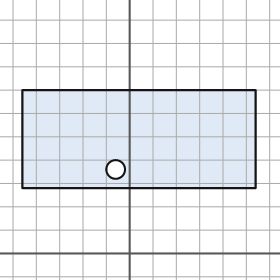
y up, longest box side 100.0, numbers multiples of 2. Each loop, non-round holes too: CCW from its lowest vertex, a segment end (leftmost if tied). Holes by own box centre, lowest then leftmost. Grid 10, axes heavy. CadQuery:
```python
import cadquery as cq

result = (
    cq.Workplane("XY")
    .moveTo(-46.0, 28.0)
    .lineTo(54.0, 28.0)
    .lineTo(54.0, 70.0)
    .lineTo(-46.0, 70.0)
    .close()
    .moveTo(-6.0, 36.0)
    .circle(4.0)
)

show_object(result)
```